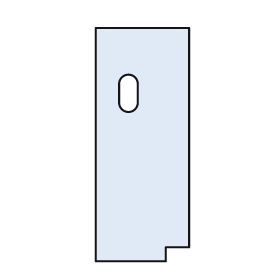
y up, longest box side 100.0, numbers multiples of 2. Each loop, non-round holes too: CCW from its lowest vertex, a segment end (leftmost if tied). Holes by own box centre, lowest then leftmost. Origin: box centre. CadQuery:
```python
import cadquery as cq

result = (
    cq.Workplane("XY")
    .moveTo(-20.0, -50.0)
    .lineTo(10.0, -50.0)
    .lineTo(10.0, -44.0)
    .lineTo(20.0, -44.0)
    .lineTo(20.0, 50.0)
    .lineTo(-20.0, 50.0)
    .close()
    .moveTo(-10.0, 18.0)
    .threePointArc((-6.0, 14.0), (-2.0, 18.0))
    .lineTo(-2.0, 26.0)
    .threePointArc((-6.0, 30.0), (-10.0, 26.0))
    .close()
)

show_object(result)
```